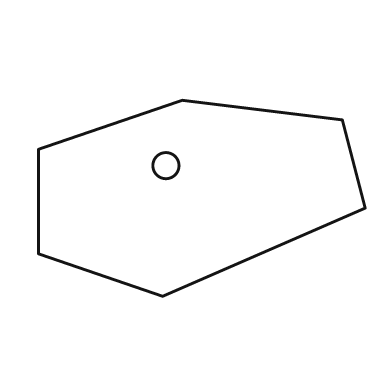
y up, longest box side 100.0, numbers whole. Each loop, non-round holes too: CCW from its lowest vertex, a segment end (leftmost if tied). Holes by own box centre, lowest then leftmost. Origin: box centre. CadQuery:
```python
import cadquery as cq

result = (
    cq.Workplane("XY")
    .moveTo(-12.0, -30.0)
    .lineTo(50.0, -3.0)
    .lineTo(43.0, 24.0)
    .lineTo(-6.0, 30.0)
    .lineTo(-50.0, 15.0)
    .lineTo(-50.0, -17.0)
    .close()
    .moveTo(-11.0, 10.0)
    .circle(4.0)
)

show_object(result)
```